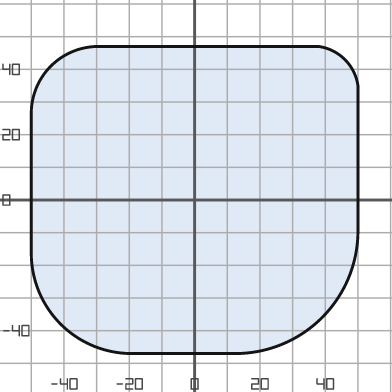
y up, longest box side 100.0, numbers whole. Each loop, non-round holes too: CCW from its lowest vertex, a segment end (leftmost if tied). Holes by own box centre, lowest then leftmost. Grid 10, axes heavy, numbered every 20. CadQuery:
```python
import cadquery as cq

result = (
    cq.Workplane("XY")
    .moveTo(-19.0, -47.0)
    .lineTo(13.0, -47.0)
    .threePointArc((39.0, -36.0), (50.0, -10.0))
    .lineTo(50.0, 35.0)
    .threePointArc((46.0, 43.0), (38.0, 47.0))
    .lineTo(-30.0, 47.0)
    .threePointArc((-44.0, 41.0), (-50.0, 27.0))
    .lineTo(-50.0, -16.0)
    .threePointArc((-41.0, -38.0), (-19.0, -47.0))
    .close()
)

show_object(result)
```